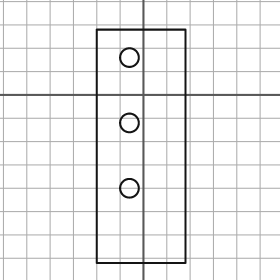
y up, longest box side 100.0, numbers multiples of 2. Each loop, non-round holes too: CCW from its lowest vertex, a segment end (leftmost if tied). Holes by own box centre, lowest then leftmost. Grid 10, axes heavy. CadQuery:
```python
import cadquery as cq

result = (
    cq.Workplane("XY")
    .moveTo(-20.0, -72.0)
    .lineTo(18.0, -72.0)
    .lineTo(18.0, 28.0)
    .lineTo(-20.0, 28.0)
    .close()
    .moveTo(-6.0, -40.0)
    .circle(4.0)
    .moveTo(-6.0, -12.0)
    .circle(4.0)
    .moveTo(-6.0, 16.0)
    .circle(4.0)
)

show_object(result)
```